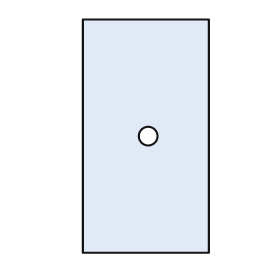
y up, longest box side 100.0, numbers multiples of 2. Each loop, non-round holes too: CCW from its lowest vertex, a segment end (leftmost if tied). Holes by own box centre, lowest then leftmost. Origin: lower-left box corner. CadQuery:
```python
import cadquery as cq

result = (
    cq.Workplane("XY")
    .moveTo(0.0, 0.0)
    .lineTo(54.0, 0.0)
    .lineTo(54.0, 100.0)
    .lineTo(0.0, 100.0)
    .close()
    .moveTo(28.0, 50.0)
    .circle(4.0)
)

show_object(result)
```